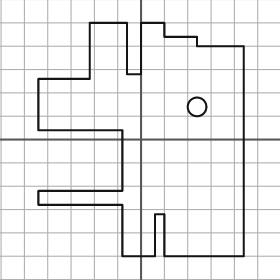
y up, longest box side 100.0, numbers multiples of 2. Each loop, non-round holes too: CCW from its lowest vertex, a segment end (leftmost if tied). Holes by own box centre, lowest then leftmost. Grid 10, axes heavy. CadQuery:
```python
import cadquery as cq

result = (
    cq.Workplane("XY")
    .moveTo(-8.0, -50.0)
    .lineTo(6.0, -50.0)
    .lineTo(6.0, -32.0)
    .lineTo(10.0, -32.0)
    .lineTo(10.0, -50.0)
    .lineTo(44.0, -50.0)
    .lineTo(44.0, 40.0)
    .lineTo(24.0, 40.0)
    .lineTo(24.0, 44.0)
    .lineTo(10.0, 44.0)
    .lineTo(10.0, 50.0)
    .lineTo(0.0, 50.0)
    .lineTo(0.0, 28.0)
    .lineTo(-6.0, 28.0)
    .lineTo(-6.0, 50.0)
    .lineTo(-22.0, 50.0)
    .lineTo(-22.0, 26.0)
    .lineTo(-44.0, 26.0)
    .lineTo(-44.0, 4.0)
    .lineTo(-8.0, 4.0)
    .lineTo(-8.0, -22.0)
    .lineTo(-44.0, -22.0)
    .lineTo(-44.0, -28.0)
    .lineTo(-8.0, -28.0)
    .close()
    .moveTo(24.0, 14.0)
    .circle(4.0)
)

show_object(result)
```